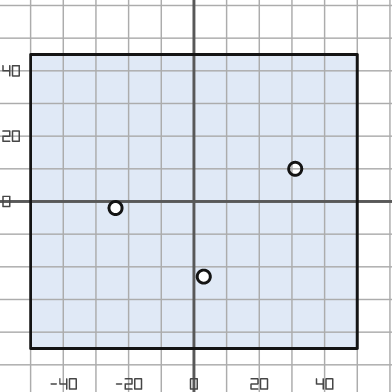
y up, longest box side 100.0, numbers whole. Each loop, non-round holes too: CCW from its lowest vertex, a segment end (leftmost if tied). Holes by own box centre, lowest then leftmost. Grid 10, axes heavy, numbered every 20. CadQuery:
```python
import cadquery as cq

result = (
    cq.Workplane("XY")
    .moveTo(-50.0, -45.0)
    .lineTo(50.0, -45.0)
    .lineTo(50.0, 45.0)
    .lineTo(-50.0, 45.0)
    .close()
    .moveTo(3.0, -23.0)
    .circle(2.0)
    .moveTo(-24.0, -2.0)
    .circle(2.0)
    .moveTo(31.0, 10.0)
    .circle(2.0)
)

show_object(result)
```